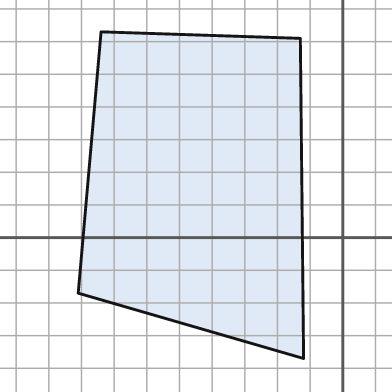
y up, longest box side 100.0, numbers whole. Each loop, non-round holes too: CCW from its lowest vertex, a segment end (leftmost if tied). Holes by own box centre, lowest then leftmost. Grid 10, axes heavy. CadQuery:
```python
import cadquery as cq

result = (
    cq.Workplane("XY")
    .moveTo(-12.0, -37.0)
    .lineTo(-13.0, 61.0)
    .lineTo(-74.0, 63.0)
    .lineTo(-81.0, -17.0)
    .close()
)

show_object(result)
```